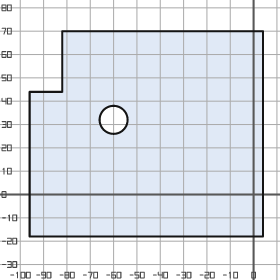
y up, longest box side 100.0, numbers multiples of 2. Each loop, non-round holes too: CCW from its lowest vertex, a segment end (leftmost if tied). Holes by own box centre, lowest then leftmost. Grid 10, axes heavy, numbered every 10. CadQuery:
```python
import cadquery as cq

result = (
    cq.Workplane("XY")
    .moveTo(-96.0, -18.0)
    .lineTo(4.0, -18.0)
    .lineTo(4.0, 70.0)
    .lineTo(-82.0, 70.0)
    .lineTo(-82.0, 44.0)
    .lineTo(-96.0, 44.0)
    .close()
    .moveTo(-60.0, 32.0)
    .circle(6.0)
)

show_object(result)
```